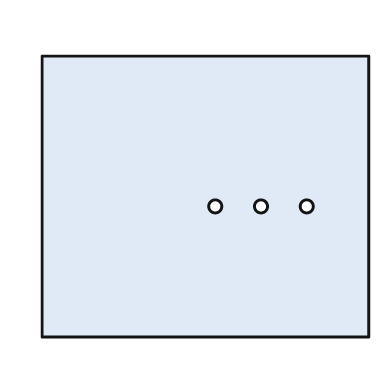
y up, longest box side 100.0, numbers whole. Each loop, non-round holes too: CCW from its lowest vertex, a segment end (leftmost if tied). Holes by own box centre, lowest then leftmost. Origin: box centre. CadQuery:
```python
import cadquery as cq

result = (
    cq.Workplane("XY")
    .moveTo(-50.0, -43.0)
    .lineTo(50.0, -43.0)
    .lineTo(50.0, 43.0)
    .lineTo(-50.0, 43.0)
    .close()
    .moveTo(3.0, -3.0)
    .circle(2.0)
    .moveTo(17.0, -3.0)
    .circle(2.0)
    .moveTo(31.0, -3.0)
    .circle(2.0)
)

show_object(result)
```